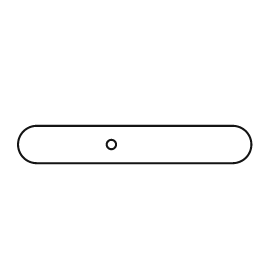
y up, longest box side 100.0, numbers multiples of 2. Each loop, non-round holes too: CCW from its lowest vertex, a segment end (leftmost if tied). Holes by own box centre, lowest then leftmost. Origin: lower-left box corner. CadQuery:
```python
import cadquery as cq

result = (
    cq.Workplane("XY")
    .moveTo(8.0, 0.0)
    .lineTo(92.0, 0.0)
    .threePointArc((100.0, 8.0), (92.0, 16.0))
    .lineTo(8.0, 16.0)
    .threePointArc((0.0, 8.0), (8.0, 0.0))
    .close()
    .moveTo(40.0, 8.0)
    .circle(2.0)
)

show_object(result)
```